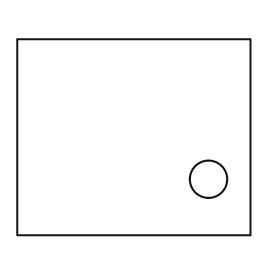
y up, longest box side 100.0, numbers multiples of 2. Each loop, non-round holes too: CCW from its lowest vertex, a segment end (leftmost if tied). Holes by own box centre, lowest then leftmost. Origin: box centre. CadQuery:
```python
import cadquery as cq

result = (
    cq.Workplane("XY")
    .moveTo(-50.0, -42.0)
    .lineTo(50.0, -42.0)
    .lineTo(50.0, 42.0)
    .lineTo(-50.0, 42.0)
    .close()
    .moveTo(32.0, -18.0)
    .circle(8.0)
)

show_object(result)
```